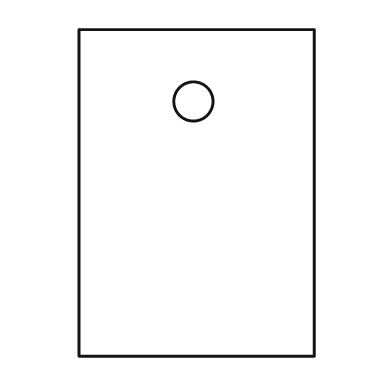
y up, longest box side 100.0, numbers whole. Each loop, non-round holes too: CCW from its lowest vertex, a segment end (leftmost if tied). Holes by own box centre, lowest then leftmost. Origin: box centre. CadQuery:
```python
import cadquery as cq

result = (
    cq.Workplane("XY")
    .moveTo(-36.0, -50.0)
    .lineTo(36.0, -50.0)
    .lineTo(36.0, 50.0)
    .lineTo(-36.0, 50.0)
    .close()
    .moveTo(-1.0, 28.0)
    .circle(6.0)
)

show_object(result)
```